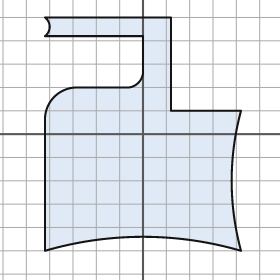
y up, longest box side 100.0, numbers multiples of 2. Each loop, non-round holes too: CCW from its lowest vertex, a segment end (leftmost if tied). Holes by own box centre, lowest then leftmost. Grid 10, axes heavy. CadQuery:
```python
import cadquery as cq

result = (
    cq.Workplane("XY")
    .moveTo(-42.0, -50.0)
    .threePointArc((0.0, -44.0), (42.0, -50.0))
    .threePointArc((38.0, -20.0), (42.0, 10.0))
    .lineTo(12.0, 10.0)
    .lineTo(12.0, 50.0)
    .lineTo(-42.0, 50.0)
    .threePointArc((-40.0, 46.0), (-42.0, 42.0))
    .lineTo(0.0, 42.0)
    .lineTo(0.0, 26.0)
    .threePointArc((-2.0, 22.0), (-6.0, 20.0))
    .lineTo(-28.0, 20.0)
    .threePointArc((-38.0, 16.0), (-42.0, 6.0))
    .close()
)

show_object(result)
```